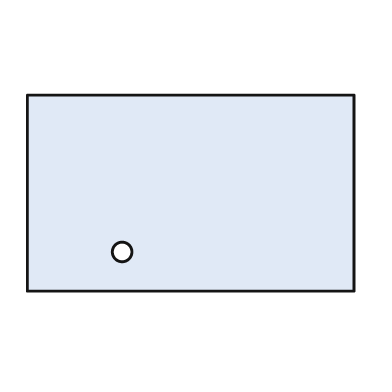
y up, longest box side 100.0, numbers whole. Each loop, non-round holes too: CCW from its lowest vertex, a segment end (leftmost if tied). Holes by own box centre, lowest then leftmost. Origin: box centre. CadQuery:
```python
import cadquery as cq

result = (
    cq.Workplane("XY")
    .moveTo(-50.0, -30.0)
    .lineTo(50.0, -30.0)
    .lineTo(50.0, 30.0)
    .lineTo(-50.0, 30.0)
    .close()
    .moveTo(-21.0, -18.0)
    .circle(3.0)
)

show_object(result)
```